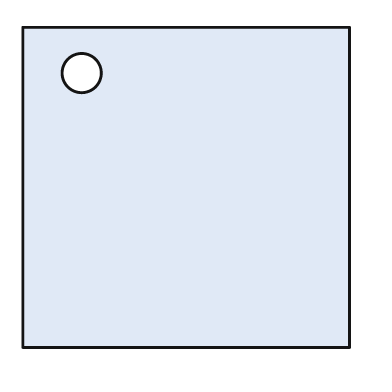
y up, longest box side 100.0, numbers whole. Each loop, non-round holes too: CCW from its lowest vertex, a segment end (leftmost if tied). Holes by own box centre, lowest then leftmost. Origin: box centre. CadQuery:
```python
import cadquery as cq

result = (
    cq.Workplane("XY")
    .moveTo(-50.0, -49.0)
    .lineTo(50.0, -49.0)
    .lineTo(50.0, 49.0)
    .lineTo(-50.0, 49.0)
    .close()
    .moveTo(-32.0, 35.0)
    .circle(6.0)
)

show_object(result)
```